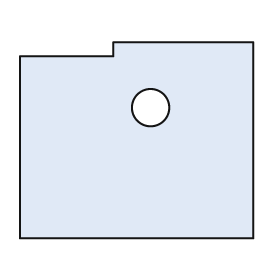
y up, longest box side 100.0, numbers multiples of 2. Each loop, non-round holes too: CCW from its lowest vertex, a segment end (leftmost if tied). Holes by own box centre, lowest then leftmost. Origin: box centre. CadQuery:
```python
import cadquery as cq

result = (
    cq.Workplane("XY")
    .moveTo(-50.0, -42.0)
    .lineTo(50.0, -42.0)
    .lineTo(50.0, 42.0)
    .lineTo(-10.0, 42.0)
    .lineTo(-10.0, 36.0)
    .lineTo(-50.0, 36.0)
    .close()
    .moveTo(6.0, 14.0)
    .circle(8.0)
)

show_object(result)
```